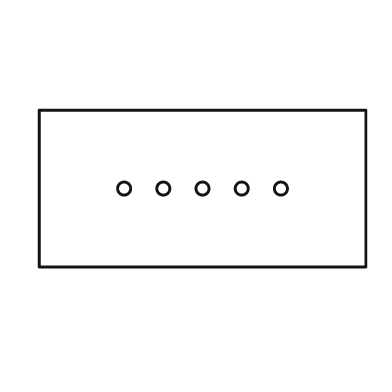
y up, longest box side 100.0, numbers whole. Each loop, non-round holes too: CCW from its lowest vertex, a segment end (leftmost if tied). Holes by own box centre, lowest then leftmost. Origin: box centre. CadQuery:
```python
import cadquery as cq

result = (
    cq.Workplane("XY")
    .moveTo(-50.0, -24.0)
    .lineTo(50.0, -24.0)
    .lineTo(50.0, 24.0)
    .lineTo(-50.0, 24.0)
    .close()
    .moveTo(-24.0, 0.0)
    .circle(2.0)
    .moveTo(-12.0, 0.0)
    .circle(2.0)
    .moveTo(0.0, 0.0)
    .circle(2.0)
    .moveTo(12.0, 0.0)
    .circle(2.0)
    .moveTo(24.0, 0.0)
    .circle(2.0)
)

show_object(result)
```